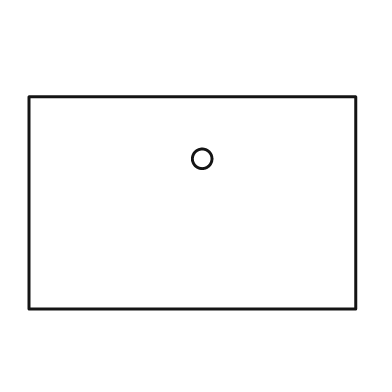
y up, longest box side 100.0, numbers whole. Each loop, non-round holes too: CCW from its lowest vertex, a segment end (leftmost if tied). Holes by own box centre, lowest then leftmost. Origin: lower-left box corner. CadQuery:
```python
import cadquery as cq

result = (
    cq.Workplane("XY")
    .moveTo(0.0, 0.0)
    .lineTo(100.0, 0.0)
    .lineTo(100.0, 65.0)
    .lineTo(0.0, 65.0)
    .close()
    .moveTo(53.0, 46.0)
    .circle(3.0)
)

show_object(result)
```